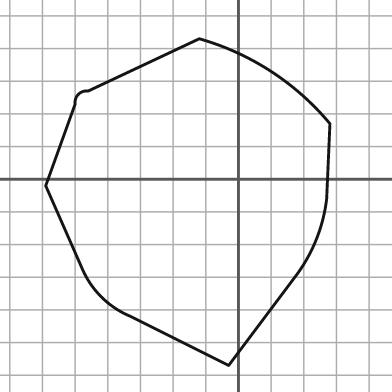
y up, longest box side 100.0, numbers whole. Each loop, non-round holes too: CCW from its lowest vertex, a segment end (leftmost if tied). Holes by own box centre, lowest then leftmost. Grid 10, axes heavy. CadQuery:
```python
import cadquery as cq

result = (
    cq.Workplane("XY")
    .moveTo(-3.0, -57.0)
    .lineTo(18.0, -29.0)
    .threePointArc((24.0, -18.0), (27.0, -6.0))
    .lineTo(28.0, 17.0)
    .threePointArc((10.0, 33.0), (-12.0, 43.0))
    .lineTo(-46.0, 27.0)
    .threePointArc((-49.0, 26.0), (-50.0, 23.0))
    .lineTo(-59.0, -2.0)
    .lineTo(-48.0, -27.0)
    .threePointArc((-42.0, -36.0), (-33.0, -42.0))
    .close()
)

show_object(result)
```